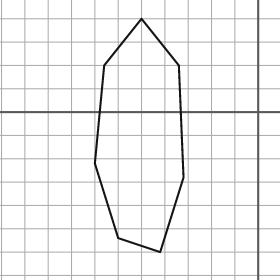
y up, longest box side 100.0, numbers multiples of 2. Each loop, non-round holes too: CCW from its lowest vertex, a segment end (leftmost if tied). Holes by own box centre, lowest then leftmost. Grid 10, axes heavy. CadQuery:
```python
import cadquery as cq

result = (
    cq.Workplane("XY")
    .moveTo(-42.0, -60.0)
    .lineTo(-32.0, -28.0)
    .lineTo(-34.0, 20.0)
    .lineTo(-50.0, 40.0)
    .lineTo(-66.0, 20.0)
    .lineTo(-70.0, -22.0)
    .lineTo(-60.0, -54.0)
    .close()
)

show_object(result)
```